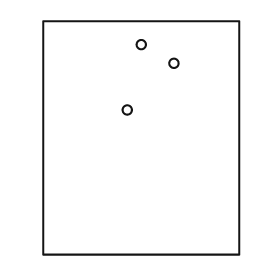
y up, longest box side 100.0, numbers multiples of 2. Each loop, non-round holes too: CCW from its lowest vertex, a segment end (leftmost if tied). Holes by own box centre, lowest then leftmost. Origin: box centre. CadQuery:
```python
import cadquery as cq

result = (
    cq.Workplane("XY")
    .moveTo(-42.0, -50.0)
    .lineTo(42.0, -50.0)
    .lineTo(42.0, 50.0)
    .lineTo(-42.0, 50.0)
    .close()
    .moveTo(-6.0, 12.0)
    .circle(2.0)
    .moveTo(14.0, 32.0)
    .circle(2.0)
    .moveTo(0.0, 40.0)
    .circle(2.0)
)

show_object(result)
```